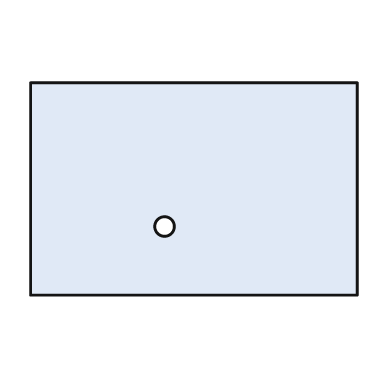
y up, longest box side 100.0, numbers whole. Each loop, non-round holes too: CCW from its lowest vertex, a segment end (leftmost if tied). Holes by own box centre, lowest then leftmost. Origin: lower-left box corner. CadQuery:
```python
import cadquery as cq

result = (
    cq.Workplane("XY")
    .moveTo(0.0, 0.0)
    .lineTo(100.0, 0.0)
    .lineTo(100.0, 65.0)
    .lineTo(0.0, 65.0)
    .close()
    .moveTo(41.0, 21.0)
    .circle(3.0)
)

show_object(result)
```